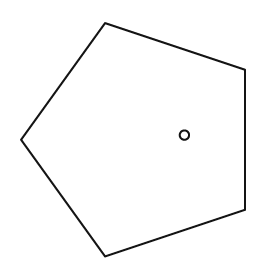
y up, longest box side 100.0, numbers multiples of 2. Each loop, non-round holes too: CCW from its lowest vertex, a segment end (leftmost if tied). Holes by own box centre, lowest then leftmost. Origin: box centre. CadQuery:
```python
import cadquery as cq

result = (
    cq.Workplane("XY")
    .moveTo(-12.0, -50.0)
    .lineTo(48.0, -30.0)
    .lineTo(48.0, 30.0)
    .lineTo(-12.0, 50.0)
    .lineTo(-48.0, 0.0)
    .close()
    .moveTo(22.0, 2.0)
    .circle(2.0)
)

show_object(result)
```